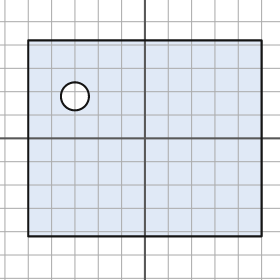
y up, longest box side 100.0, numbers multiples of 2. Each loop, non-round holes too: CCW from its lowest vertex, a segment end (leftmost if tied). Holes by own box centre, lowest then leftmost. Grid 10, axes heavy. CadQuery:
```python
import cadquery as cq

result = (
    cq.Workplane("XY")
    .moveTo(-50.0, -42.0)
    .lineTo(50.0, -42.0)
    .lineTo(50.0, 42.0)
    .lineTo(-50.0, 42.0)
    .close()
    .moveTo(-30.0, 18.0)
    .circle(6.0)
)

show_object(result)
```